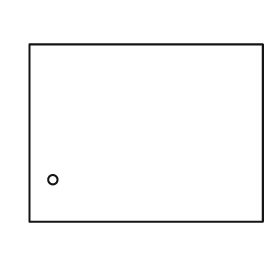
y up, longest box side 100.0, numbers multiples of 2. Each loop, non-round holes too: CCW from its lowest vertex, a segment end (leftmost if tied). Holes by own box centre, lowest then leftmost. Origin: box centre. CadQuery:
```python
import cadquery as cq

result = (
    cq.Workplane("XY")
    .moveTo(-50.0, -38.0)
    .lineTo(50.0, -38.0)
    .lineTo(50.0, 38.0)
    .lineTo(-50.0, 38.0)
    .close()
    .moveTo(-40.0, -20.0)
    .circle(2.0)
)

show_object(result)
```